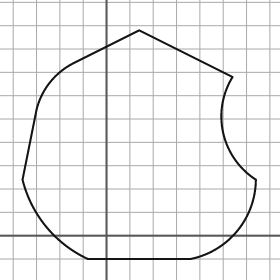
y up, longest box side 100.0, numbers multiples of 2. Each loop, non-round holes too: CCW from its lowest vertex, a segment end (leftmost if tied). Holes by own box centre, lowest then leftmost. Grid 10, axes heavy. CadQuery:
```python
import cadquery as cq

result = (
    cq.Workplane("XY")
    .moveTo(-8.0, -10.0)
    .lineTo(36.0, -10.0)
    .threePointArc((56.0, 2.0), (64.0, 24.0))
    .threePointArc((50.0, 44.0), (54.0, 68.0))
    .lineTo(14.0, 88.0)
    .lineTo(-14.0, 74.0)
    .threePointArc((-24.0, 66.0), (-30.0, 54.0))
    .lineTo(-36.0, 24.0)
    .threePointArc((-26.0, 4.0), (-8.0, -10.0))
    .close()
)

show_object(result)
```